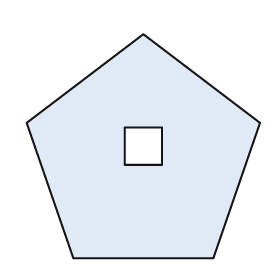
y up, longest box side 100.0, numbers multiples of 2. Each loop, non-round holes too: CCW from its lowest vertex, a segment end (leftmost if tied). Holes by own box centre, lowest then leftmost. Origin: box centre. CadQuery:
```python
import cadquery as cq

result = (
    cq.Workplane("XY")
    .moveTo(-30.0, -48.0)
    .lineTo(30.0, -48.0)
    .lineTo(50.0, 10.0)
    .lineTo(0.0, 48.0)
    .lineTo(-50.0, 10.0)
    .close()
    .moveTo(-8.0, -8.0)
    .lineTo(8.0, -8.0)
    .lineTo(8.0, 8.0)
    .lineTo(-8.0, 8.0)
    .close()
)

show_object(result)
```